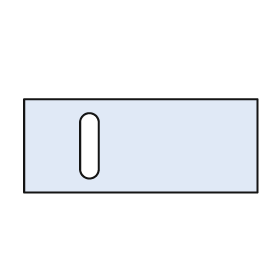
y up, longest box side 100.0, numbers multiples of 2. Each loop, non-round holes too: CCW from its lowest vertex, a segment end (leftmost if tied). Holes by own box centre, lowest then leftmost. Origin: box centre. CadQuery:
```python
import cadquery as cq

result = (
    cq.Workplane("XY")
    .moveTo(-50.0, -20.0)
    .lineTo(50.0, -20.0)
    .lineTo(50.0, 20.0)
    .lineTo(-50.0, 20.0)
    .close()
    .moveTo(-26.0, -10.0)
    .threePointArc((-22.0, -14.0), (-18.0, -10.0))
    .lineTo(-18.0, 10.0)
    .threePointArc((-22.0, 14.0), (-26.0, 10.0))
    .close()
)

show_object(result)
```